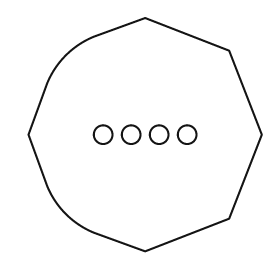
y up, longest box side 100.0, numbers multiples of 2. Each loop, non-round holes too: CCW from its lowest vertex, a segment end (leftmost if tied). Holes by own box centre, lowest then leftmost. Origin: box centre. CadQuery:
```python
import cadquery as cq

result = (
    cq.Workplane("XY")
    .moveTo(0.0, -50.0)
    .lineTo(36.0, -36.0)
    .lineTo(50.0, 0.0)
    .lineTo(36.0, 36.0)
    .lineTo(0.0, 50.0)
    .lineTo(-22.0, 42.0)
    .threePointArc((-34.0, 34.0), (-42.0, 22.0))
    .lineTo(-50.0, 0.0)
    .lineTo(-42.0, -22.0)
    .threePointArc((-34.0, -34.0), (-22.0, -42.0))
    .close()
    .moveTo(-18.0, 0.0)
    .circle(4.0)
    .moveTo(-6.0, 0.0)
    .circle(4.0)
    .moveTo(6.0, 0.0)
    .circle(4.0)
    .moveTo(18.0, 0.0)
    .circle(4.0)
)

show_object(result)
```